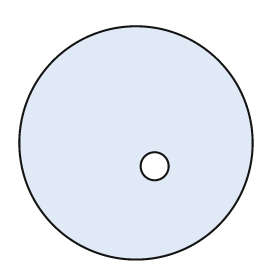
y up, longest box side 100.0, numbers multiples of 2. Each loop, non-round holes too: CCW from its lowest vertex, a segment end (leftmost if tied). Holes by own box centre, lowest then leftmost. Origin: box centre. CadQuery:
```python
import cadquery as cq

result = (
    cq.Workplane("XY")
    .moveTo(0.0, 0.0)
    .circle(50.0)
    .moveTo(8.0, -10.0)
    .circle(6.0)
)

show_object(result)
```